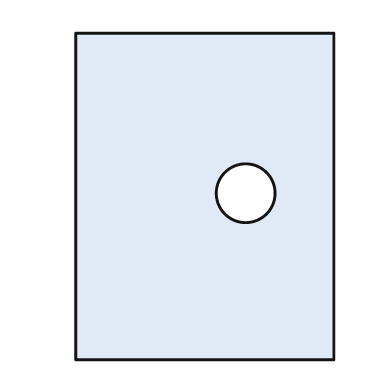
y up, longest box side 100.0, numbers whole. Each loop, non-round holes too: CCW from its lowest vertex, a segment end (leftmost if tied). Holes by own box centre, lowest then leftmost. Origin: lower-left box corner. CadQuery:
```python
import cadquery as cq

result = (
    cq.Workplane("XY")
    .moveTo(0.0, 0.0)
    .lineTo(79.0, 0.0)
    .lineTo(79.0, 100.0)
    .lineTo(0.0, 100.0)
    .close()
    .moveTo(52.0, 51.0)
    .circle(9.0)
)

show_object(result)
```